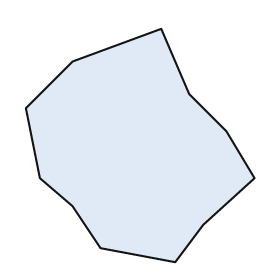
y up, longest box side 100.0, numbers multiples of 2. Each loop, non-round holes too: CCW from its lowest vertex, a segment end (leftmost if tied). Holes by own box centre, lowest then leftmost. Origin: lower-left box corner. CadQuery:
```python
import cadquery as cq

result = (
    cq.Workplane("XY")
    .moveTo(64.0, 0.0)
    .lineTo(76.0, 16.0)
    .lineTo(98.0, 36.0)
    .lineTo(86.0, 56.0)
    .lineTo(70.0, 72.0)
    .lineTo(58.0, 100.0)
    .lineTo(20.0, 86.0)
    .lineTo(0.0, 66.0)
    .lineTo(6.0, 36.0)
    .lineTo(20.0, 24.0)
    .lineTo(32.0, 6.0)
    .close()
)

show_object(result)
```